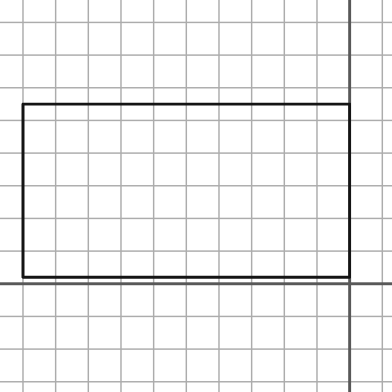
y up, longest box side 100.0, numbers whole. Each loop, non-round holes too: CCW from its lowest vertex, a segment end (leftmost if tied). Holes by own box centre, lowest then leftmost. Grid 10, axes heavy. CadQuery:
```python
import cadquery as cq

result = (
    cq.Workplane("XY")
    .moveTo(-100.0, 2.0)
    .lineTo(0.0, 2.0)
    .lineTo(0.0, 55.0)
    .lineTo(-100.0, 55.0)
    .close()
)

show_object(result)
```